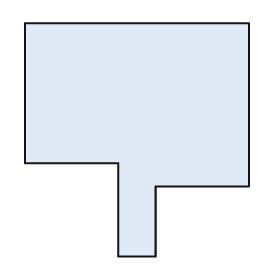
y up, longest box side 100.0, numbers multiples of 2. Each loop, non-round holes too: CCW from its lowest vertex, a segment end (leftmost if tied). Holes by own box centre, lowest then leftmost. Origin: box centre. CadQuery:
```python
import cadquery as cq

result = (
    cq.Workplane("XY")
    .moveTo(-8.0, -50.0)
    .lineTo(8.0, -50.0)
    .lineTo(8.0, -20.0)
    .lineTo(48.0, -20.0)
    .lineTo(48.0, 50.0)
    .lineTo(-48.0, 50.0)
    .lineTo(-48.0, -10.0)
    .lineTo(-8.0, -10.0)
    .close()
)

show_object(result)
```